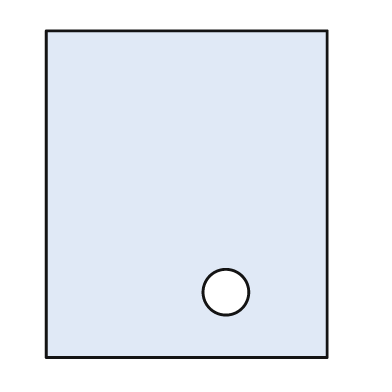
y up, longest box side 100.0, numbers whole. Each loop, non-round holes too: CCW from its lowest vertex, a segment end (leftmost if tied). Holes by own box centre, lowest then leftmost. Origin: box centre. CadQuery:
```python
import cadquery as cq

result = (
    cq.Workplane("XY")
    .moveTo(-43.0, -50.0)
    .lineTo(43.0, -50.0)
    .lineTo(43.0, 50.0)
    .lineTo(-43.0, 50.0)
    .close()
    .moveTo(12.0, -30.0)
    .circle(7.0)
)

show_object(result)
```